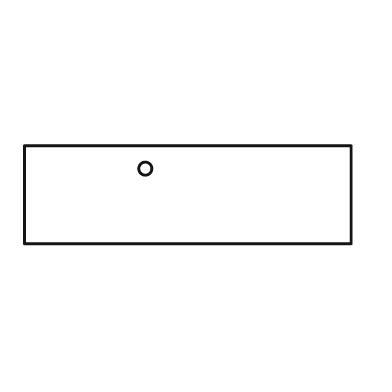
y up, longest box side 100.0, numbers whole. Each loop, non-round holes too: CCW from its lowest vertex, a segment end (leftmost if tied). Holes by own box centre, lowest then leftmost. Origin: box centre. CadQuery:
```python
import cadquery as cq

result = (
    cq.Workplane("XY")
    .moveTo(-50.0, -15.0)
    .lineTo(50.0, -15.0)
    .lineTo(50.0, 15.0)
    .lineTo(-50.0, 15.0)
    .close()
    .moveTo(-13.0, 8.0)
    .circle(2.0)
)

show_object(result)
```